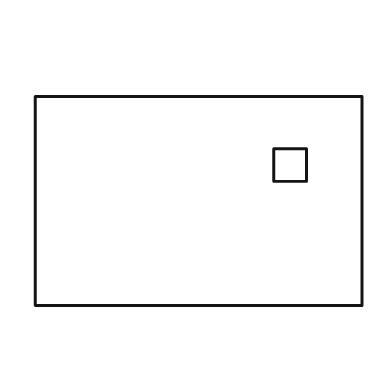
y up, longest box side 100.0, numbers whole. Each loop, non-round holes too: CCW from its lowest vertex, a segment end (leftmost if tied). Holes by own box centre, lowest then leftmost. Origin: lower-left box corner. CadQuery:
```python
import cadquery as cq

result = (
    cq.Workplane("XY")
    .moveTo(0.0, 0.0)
    .lineTo(100.0, 0.0)
    .lineTo(100.0, 64.0)
    .lineTo(0.0, 64.0)
    .close()
    .moveTo(73.0, 38.0)
    .lineTo(83.0, 38.0)
    .lineTo(83.0, 48.0)
    .lineTo(73.0, 48.0)
    .close()
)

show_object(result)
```